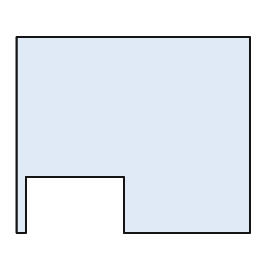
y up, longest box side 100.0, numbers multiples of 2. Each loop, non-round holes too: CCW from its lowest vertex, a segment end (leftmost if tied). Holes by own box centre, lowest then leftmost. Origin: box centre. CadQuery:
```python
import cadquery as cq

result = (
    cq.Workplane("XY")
    .moveTo(-50.0, -42.0)
    .lineTo(-46.0, -42.0)
    .lineTo(-46.0, -18.0)
    .lineTo(-4.0, -18.0)
    .lineTo(-4.0, -42.0)
    .lineTo(50.0, -42.0)
    .lineTo(50.0, 42.0)
    .lineTo(-50.0, 42.0)
    .close()
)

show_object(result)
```